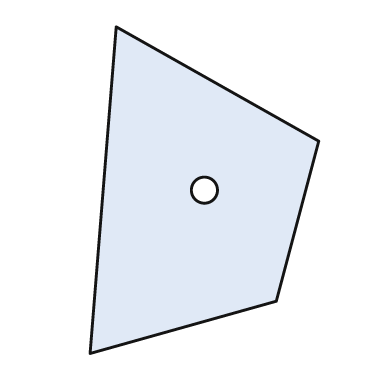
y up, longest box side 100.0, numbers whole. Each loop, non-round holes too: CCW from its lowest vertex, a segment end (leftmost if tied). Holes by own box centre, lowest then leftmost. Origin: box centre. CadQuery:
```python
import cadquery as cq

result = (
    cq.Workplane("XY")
    .moveTo(-35.0, -50.0)
    .lineTo(22.0, -34.0)
    .lineTo(35.0, 15.0)
    .lineTo(-27.0, 50.0)
    .close()
    .moveTo(0.0, 0.0)
    .circle(4.0)
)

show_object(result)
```